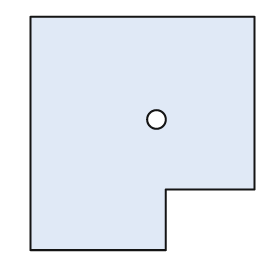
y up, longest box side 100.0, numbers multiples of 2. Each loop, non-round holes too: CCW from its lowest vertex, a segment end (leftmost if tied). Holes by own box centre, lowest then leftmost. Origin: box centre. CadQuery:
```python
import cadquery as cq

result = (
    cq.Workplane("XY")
    .moveTo(-48.0, -50.0)
    .lineTo(10.0, -50.0)
    .lineTo(10.0, -24.0)
    .lineTo(48.0, -24.0)
    .lineTo(48.0, 50.0)
    .lineTo(-48.0, 50.0)
    .close()
    .moveTo(6.0, 6.0)
    .circle(4.0)
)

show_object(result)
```